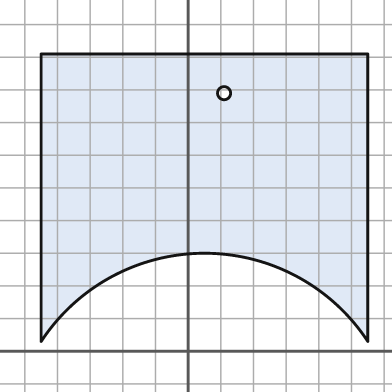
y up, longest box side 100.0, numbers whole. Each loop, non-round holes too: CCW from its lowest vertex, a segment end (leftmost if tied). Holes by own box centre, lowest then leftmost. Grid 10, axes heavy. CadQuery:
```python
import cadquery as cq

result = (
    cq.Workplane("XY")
    .moveTo(-45.0, 3.0)
    .threePointArc((5.0, 30.0), (55.0, 3.0))
    .lineTo(55.0, 91.0)
    .lineTo(-45.0, 91.0)
    .close()
    .moveTo(11.0, 79.0)
    .circle(2.0)
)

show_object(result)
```